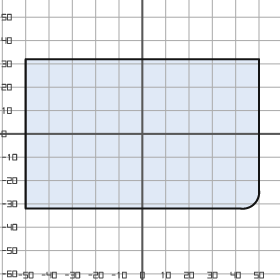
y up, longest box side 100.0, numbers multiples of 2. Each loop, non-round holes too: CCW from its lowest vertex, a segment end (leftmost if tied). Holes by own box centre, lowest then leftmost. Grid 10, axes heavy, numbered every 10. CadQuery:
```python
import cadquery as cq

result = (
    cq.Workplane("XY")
    .moveTo(-50.0, -32.0)
    .lineTo(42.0, -32.0)
    .threePointArc((48.0, -30.0), (50.0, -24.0))
    .lineTo(50.0, 32.0)
    .lineTo(-50.0, 32.0)
    .close()
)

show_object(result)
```